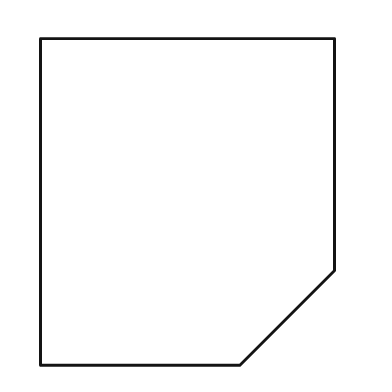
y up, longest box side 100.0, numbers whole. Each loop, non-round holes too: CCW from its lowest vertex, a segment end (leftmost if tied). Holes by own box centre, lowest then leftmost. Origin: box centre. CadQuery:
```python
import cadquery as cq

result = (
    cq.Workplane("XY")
    .moveTo(-45.0, -50.0)
    .lineTo(16.0, -50.0)
    .lineTo(45.0, -21.0)
    .lineTo(45.0, 50.0)
    .lineTo(-45.0, 50.0)
    .close()
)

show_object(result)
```